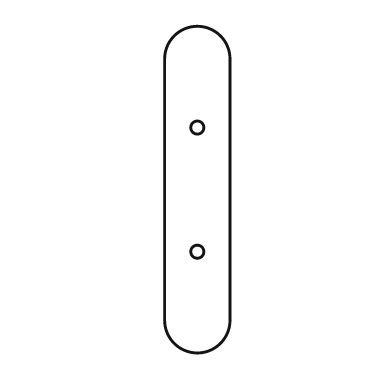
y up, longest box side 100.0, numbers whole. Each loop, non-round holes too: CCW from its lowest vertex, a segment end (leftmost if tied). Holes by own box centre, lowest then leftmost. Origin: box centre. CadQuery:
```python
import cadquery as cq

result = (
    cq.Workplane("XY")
    .moveTo(-10.0, -40.0)
    .threePointArc((0.0, -50.0), (10.0, -40.0))
    .lineTo(10.0, 40.0)
    .threePointArc((0.0, 50.0), (-10.0, 40.0))
    .close()
    .moveTo(0.0, -19.0)
    .circle(2.0)
    .moveTo(0.0, 19.0)
    .circle(2.0)
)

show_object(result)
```